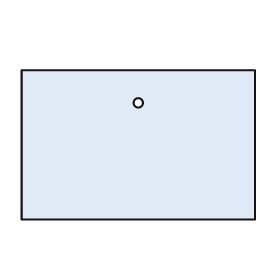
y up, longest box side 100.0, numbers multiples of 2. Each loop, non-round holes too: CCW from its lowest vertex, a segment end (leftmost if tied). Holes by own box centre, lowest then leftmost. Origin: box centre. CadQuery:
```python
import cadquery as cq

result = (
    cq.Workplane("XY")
    .moveTo(-50.0, -32.0)
    .lineTo(50.0, -32.0)
    .lineTo(50.0, 32.0)
    .lineTo(-50.0, 32.0)
    .close()
    .moveTo(0.0, 18.0)
    .circle(2.0)
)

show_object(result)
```